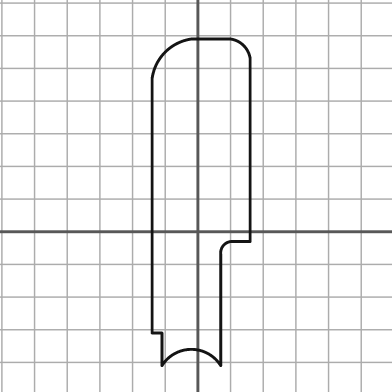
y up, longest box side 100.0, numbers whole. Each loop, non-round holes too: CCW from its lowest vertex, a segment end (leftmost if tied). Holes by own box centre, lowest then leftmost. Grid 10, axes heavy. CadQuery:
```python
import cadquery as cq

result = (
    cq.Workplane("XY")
    .moveTo(-11.0, -41.0)
    .threePointArc((-2.0, -36.0), (7.0, -41.0))
    .lineTo(7.0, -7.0)
    .threePointArc((8.0, -4.0), (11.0, -3.0))
    .lineTo(16.0, -3.0)
    .lineTo(16.0, 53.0)
    .threePointArc((14.0, 57.0), (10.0, 59.0))
    .lineTo(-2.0, 59.0)
    .threePointArc((-10.0, 55.0), (-14.0, 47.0))
    .lineTo(-14.0, -31.0)
    .lineTo(-11.0, -31.0)
    .close()
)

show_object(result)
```